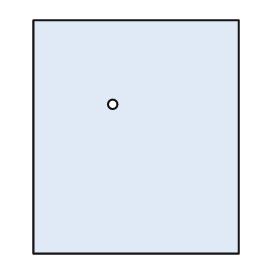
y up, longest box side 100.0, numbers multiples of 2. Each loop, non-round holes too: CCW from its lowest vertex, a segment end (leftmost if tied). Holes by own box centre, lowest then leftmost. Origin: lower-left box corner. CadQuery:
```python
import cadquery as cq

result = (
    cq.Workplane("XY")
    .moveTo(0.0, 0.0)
    .lineTo(88.0, 0.0)
    .lineTo(88.0, 100.0)
    .lineTo(0.0, 100.0)
    .close()
    .moveTo(34.0, 64.0)
    .circle(2.0)
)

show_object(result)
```